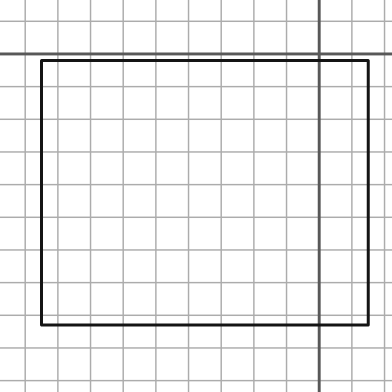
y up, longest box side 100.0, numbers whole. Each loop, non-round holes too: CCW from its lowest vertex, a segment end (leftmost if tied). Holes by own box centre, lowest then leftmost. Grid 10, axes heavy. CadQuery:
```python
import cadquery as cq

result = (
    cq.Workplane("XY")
    .moveTo(-85.0, -83.0)
    .lineTo(15.0, -83.0)
    .lineTo(15.0, -2.0)
    .lineTo(-85.0, -2.0)
    .close()
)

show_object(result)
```